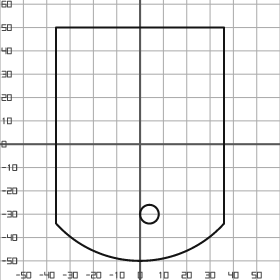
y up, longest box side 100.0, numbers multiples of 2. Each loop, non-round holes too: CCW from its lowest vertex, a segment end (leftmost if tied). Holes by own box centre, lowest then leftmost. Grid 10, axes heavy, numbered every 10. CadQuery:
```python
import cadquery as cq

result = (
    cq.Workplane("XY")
    .moveTo(-36.0, -34.0)
    .threePointArc((0.0, -50.0), (36.0, -34.0))
    .lineTo(36.0, 50.0)
    .lineTo(-36.0, 50.0)
    .close()
    .moveTo(4.0, -30.0)
    .circle(4.0)
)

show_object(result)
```